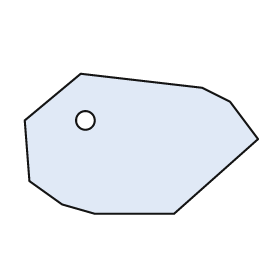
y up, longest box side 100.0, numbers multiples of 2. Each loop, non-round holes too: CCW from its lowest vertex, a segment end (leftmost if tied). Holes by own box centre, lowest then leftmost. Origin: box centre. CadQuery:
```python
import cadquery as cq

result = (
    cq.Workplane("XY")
    .moveTo(-20.0, -30.0)
    .lineTo(14.0, -30.0)
    .lineTo(50.0, 2.0)
    .lineTo(38.0, 18.0)
    .lineTo(26.0, 24.0)
    .lineTo(-26.0, 30.0)
    .lineTo(-50.0, 10.0)
    .lineTo(-48.0, -16.0)
    .lineTo(-34.0, -26.0)
    .close()
    .moveTo(-24.0, 10.0)
    .circle(4.0)
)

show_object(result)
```